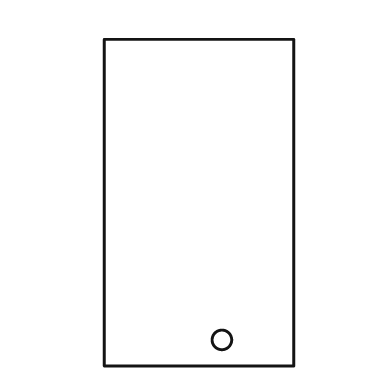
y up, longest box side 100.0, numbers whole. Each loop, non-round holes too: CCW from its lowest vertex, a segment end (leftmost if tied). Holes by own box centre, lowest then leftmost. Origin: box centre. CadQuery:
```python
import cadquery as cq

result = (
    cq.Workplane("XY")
    .moveTo(-29.0, -50.0)
    .lineTo(29.0, -50.0)
    .lineTo(29.0, 50.0)
    .lineTo(-29.0, 50.0)
    .close()
    .moveTo(7.0, -42.0)
    .circle(3.0)
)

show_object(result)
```